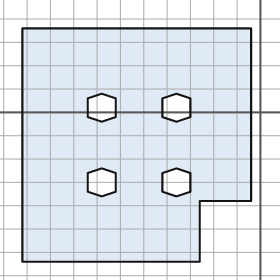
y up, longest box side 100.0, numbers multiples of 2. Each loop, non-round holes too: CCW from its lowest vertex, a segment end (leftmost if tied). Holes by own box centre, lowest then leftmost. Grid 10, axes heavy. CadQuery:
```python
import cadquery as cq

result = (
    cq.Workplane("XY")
    .moveTo(-102.0, -64.0)
    .lineTo(-26.0, -64.0)
    .lineTo(-26.0, -38.0)
    .lineTo(-4.0, -38.0)
    .lineTo(-4.0, 36.0)
    .lineTo(-102.0, 36.0)
    .close()
    .moveTo(-68.0, -36.0)
    .lineTo(-62.0, -34.0)
    .lineTo(-62.0, -26.0)
    .lineTo(-68.0, -24.0)
    .lineTo(-74.0, -26.0)
    .lineTo(-74.0, -34.0)
    .close()
    .moveTo(-36.0, -36.0)
    .lineTo(-30.0, -34.0)
    .lineTo(-30.0, -26.0)
    .lineTo(-36.0, -24.0)
    .lineTo(-42.0, -26.0)
    .lineTo(-42.0, -34.0)
    .close()
    .moveTo(-68.0, -4.0)
    .lineTo(-62.0, -2.0)
    .lineTo(-62.0, 6.0)
    .lineTo(-68.0, 8.0)
    .lineTo(-74.0, 6.0)
    .lineTo(-74.0, -2.0)
    .close()
    .moveTo(-36.0, -4.0)
    .lineTo(-30.0, -2.0)
    .lineTo(-30.0, 6.0)
    .lineTo(-36.0, 8.0)
    .lineTo(-42.0, 6.0)
    .lineTo(-42.0, -2.0)
    .close()
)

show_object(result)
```